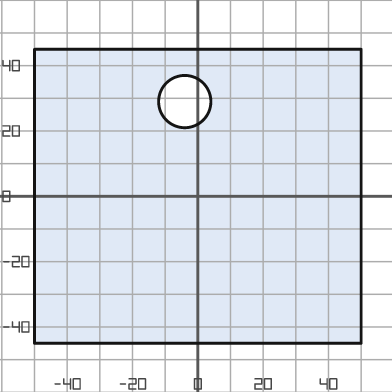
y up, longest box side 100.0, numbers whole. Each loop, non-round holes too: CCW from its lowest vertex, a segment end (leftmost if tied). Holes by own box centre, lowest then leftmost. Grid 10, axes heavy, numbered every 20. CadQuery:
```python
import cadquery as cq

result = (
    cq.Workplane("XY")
    .moveTo(-50.0, -45.0)
    .lineTo(50.0, -45.0)
    .lineTo(50.0, 45.0)
    .lineTo(-50.0, 45.0)
    .close()
    .moveTo(-4.0, 29.0)
    .circle(8.0)
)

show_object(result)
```